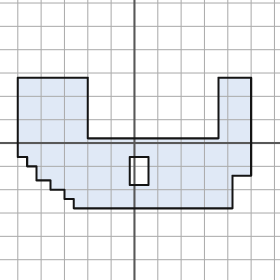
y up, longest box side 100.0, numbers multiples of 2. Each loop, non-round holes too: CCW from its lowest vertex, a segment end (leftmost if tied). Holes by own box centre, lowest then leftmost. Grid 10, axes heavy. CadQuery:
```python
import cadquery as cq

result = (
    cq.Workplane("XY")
    .moveTo(-26.0, -28.0)
    .lineTo(42.0, -28.0)
    .lineTo(42.0, -14.0)
    .lineTo(50.0, -14.0)
    .lineTo(50.0, 28.0)
    .lineTo(36.0, 28.0)
    .lineTo(36.0, 2.0)
    .lineTo(-20.0, 2.0)
    .lineTo(-20.0, 28.0)
    .lineTo(-50.0, 28.0)
    .lineTo(-50.0, -6.0)
    .lineTo(-46.0, -6.0)
    .lineTo(-46.0, -10.0)
    .lineTo(-42.0, -10.0)
    .lineTo(-42.0, -16.0)
    .lineTo(-36.0, -16.0)
    .lineTo(-36.0, -20.0)
    .lineTo(-30.0, -20.0)
    .lineTo(-30.0, -24.0)
    .lineTo(-26.0, -24.0)
    .close()
    .moveTo(-2.0, -18.0)
    .lineTo(6.0, -18.0)
    .lineTo(6.0, -6.0)
    .lineTo(-2.0, -6.0)
    .close()
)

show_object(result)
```